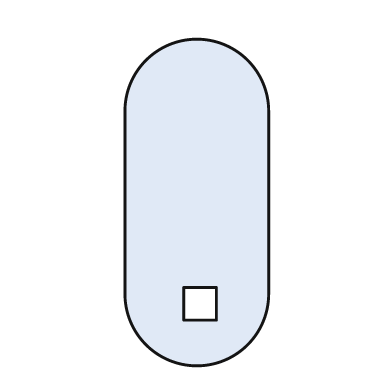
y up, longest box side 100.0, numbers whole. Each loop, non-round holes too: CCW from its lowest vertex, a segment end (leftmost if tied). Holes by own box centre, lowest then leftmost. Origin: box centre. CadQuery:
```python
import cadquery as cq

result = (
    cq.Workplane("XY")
    .moveTo(-22.0, -28.0)
    .threePointArc((0.0, -50.0), (22.0, -28.0))
    .lineTo(22.0, 28.0)
    .threePointArc((0.0, 50.0), (-22.0, 28.0))
    .close()
    .moveTo(-4.0, -36.0)
    .lineTo(6.0, -36.0)
    .lineTo(6.0, -26.0)
    .lineTo(-4.0, -26.0)
    .close()
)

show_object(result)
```